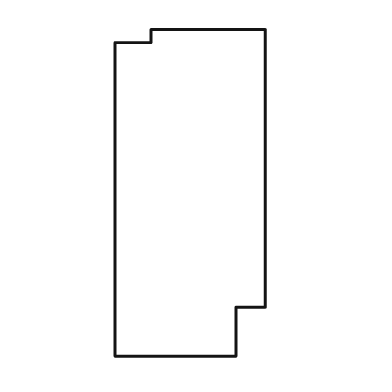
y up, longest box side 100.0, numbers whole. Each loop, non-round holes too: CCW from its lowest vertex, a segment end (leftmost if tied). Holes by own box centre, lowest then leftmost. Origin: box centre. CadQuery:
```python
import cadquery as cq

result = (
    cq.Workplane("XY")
    .moveTo(-23.0, -50.0)
    .lineTo(14.0, -50.0)
    .lineTo(14.0, -35.0)
    .lineTo(23.0, -35.0)
    .lineTo(23.0, 50.0)
    .lineTo(-12.0, 50.0)
    .lineTo(-12.0, 46.0)
    .lineTo(-23.0, 46.0)
    .close()
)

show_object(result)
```